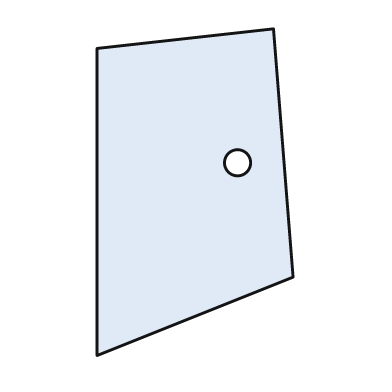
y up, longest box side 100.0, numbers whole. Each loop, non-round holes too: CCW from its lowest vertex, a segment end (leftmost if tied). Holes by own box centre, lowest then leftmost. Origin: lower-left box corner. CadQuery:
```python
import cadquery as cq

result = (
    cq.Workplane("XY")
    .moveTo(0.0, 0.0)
    .lineTo(60.0, 24.0)
    .lineTo(54.0, 100.0)
    .lineTo(0.0, 94.0)
    .close()
    .moveTo(43.0, 59.0)
    .circle(4.0)
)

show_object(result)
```